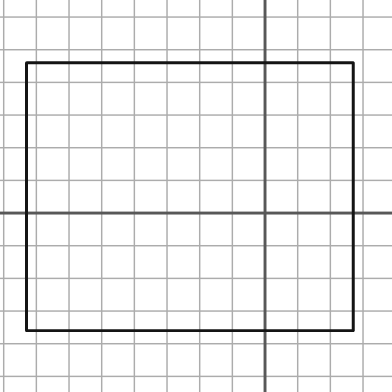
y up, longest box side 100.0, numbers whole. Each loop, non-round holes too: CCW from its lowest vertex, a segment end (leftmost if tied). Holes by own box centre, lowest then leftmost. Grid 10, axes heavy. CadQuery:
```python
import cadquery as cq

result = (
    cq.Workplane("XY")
    .moveTo(-73.0, -36.0)
    .lineTo(27.0, -36.0)
    .lineTo(27.0, 46.0)
    .lineTo(-73.0, 46.0)
    .close()
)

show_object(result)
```